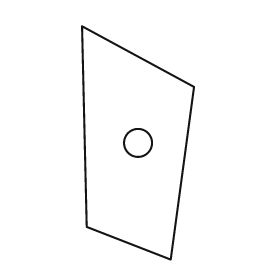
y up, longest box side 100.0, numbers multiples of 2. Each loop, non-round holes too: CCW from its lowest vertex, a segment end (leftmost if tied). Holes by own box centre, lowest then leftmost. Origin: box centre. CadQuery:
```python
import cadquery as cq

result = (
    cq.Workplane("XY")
    .moveTo(14.0, -50.0)
    .lineTo(24.0, 24.0)
    .lineTo(-24.0, 50.0)
    .lineTo(-22.0, -36.0)
    .close()
    .moveTo(0.0, 0.0)
    .circle(6.0)
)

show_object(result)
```